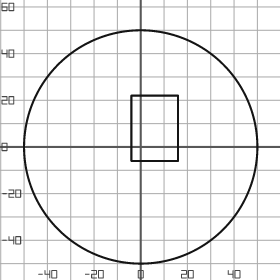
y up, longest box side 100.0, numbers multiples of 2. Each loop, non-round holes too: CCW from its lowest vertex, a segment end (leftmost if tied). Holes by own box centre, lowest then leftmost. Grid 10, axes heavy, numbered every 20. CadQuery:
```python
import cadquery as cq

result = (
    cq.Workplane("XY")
    .moveTo(0.0, 0.0)
    .circle(50.0)
    .moveTo(-4.0, -6.0)
    .lineTo(16.0, -6.0)
    .lineTo(16.0, 22.0)
    .lineTo(-4.0, 22.0)
    .close()
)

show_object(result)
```